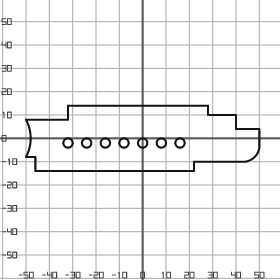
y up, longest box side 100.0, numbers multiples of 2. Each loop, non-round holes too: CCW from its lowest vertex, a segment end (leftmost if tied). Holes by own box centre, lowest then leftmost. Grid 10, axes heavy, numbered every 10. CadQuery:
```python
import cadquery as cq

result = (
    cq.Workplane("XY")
    .moveTo(-46.0, -14.0)
    .lineTo(22.0, -14.0)
    .lineTo(22.0, -10.0)
    .lineTo(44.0, -10.0)
    .threePointArc((48.0, -8.0), (50.0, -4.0))
    .lineTo(50.0, 4.0)
    .lineTo(40.0, 4.0)
    .lineTo(40.0, 10.0)
    .lineTo(28.0, 10.0)
    .lineTo(28.0, 14.0)
    .lineTo(-32.0, 14.0)
    .lineTo(-32.0, 8.0)
    .lineTo(-50.0, 8.0)
    .threePointArc((-48.0, 0.0), (-50.0, -8.0))
    .lineTo(-46.0, -8.0)
    .close()
    .moveTo(-32.0, -2.0)
    .circle(2.0)
    .moveTo(-24.0, -2.0)
    .circle(2.0)
    .moveTo(-16.0, -2.0)
    .circle(2.0)
    .moveTo(-8.0, -2.0)
    .circle(2.0)
    .moveTo(0.0, -2.0)
    .circle(2.0)
    .moveTo(8.0, -2.0)
    .circle(2.0)
    .moveTo(16.0, -2.0)
    .circle(2.0)
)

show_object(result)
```